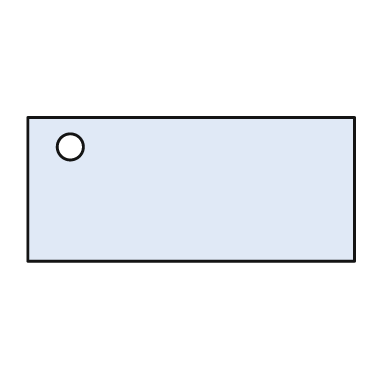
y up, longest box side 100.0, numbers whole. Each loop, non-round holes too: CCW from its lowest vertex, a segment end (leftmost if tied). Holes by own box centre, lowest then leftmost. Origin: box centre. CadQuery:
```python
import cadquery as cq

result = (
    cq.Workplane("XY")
    .moveTo(-50.0, -22.0)
    .lineTo(50.0, -22.0)
    .lineTo(50.0, 22.0)
    .lineTo(-50.0, 22.0)
    .close()
    .moveTo(-37.0, 13.0)
    .circle(4.0)
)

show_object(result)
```